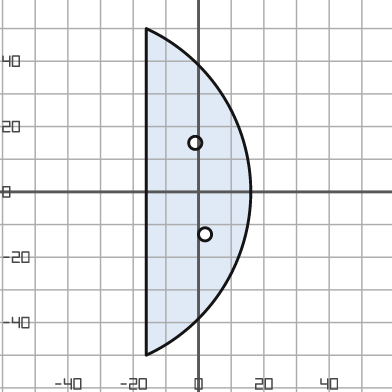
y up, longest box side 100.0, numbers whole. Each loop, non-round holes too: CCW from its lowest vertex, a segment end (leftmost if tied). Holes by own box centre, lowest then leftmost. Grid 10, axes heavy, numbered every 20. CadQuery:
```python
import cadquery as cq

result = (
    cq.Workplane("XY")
    .moveTo(-16.0, -50.0)
    .threePointArc((16.0, 0.0), (-16.0, 50.0))
    .close()
    .moveTo(2.0, -13.0)
    .circle(2.0)
    .moveTo(-1.0, 15.0)
    .circle(2.0)
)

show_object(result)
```